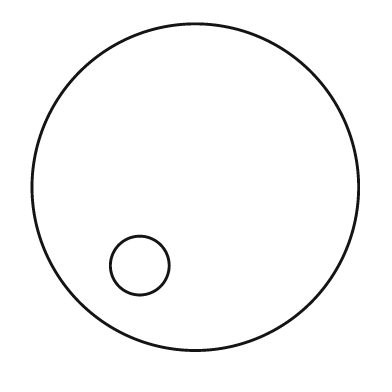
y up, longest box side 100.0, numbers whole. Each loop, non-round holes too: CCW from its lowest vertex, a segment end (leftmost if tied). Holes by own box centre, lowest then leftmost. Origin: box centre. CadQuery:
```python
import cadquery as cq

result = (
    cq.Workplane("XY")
    .moveTo(0.0, 0.0)
    .circle(50.0)
    .moveTo(-17.0, -24.0)
    .circle(9.0)
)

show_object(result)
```